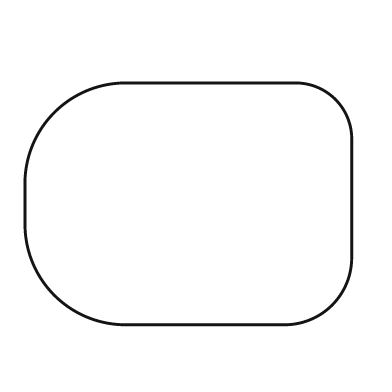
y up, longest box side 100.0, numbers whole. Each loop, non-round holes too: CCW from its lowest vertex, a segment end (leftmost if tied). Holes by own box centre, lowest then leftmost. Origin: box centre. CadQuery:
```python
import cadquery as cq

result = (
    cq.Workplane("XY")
    .moveTo(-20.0, -37.0)
    .lineTo(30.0, -37.0)
    .threePointArc((44.0, -31.0), (50.0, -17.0))
    .lineTo(50.0, 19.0)
    .threePointArc((45.0, 32.0), (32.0, 37.0))
    .lineTo(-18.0, 37.0)
    .threePointArc((-41.0, 28.0), (-50.0, 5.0))
    .lineTo(-50.0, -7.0)
    .threePointArc((-41.0, -28.0), (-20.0, -37.0))
    .close()
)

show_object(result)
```